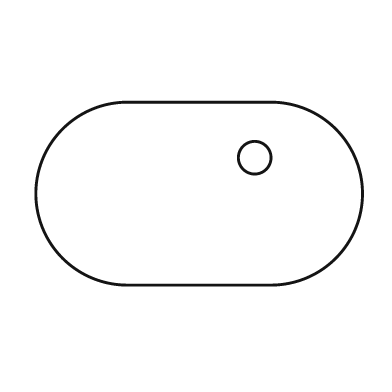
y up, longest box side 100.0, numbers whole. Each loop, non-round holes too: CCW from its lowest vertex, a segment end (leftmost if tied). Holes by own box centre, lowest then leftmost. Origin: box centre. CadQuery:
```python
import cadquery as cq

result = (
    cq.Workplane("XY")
    .moveTo(-22.0, -28.0)
    .lineTo(22.0, -28.0)
    .threePointArc((50.0, 0.0), (22.0, 28.0))
    .lineTo(-22.0, 28.0)
    .threePointArc((-50.0, 0.0), (-22.0, -28.0))
    .close()
    .moveTo(17.0, 11.0)
    .circle(5.0)
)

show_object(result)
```